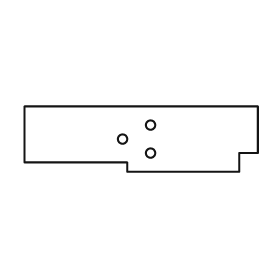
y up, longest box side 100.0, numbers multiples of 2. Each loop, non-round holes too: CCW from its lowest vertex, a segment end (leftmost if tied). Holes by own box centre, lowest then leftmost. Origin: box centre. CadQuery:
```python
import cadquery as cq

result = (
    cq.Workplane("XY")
    .moveTo(-6.0, -14.0)
    .lineTo(42.0, -14.0)
    .lineTo(42.0, -6.0)
    .lineTo(50.0, -6.0)
    .lineTo(50.0, 14.0)
    .lineTo(-50.0, 14.0)
    .lineTo(-50.0, -10.0)
    .lineTo(-6.0, -10.0)
    .close()
    .moveTo(4.0, -6.0)
    .circle(2.0)
    .moveTo(-8.0, 0.0)
    .circle(2.0)
    .moveTo(4.0, 6.0)
    .circle(2.0)
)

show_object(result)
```